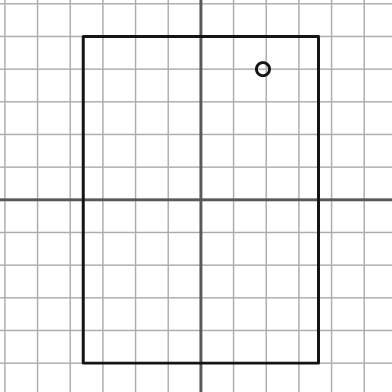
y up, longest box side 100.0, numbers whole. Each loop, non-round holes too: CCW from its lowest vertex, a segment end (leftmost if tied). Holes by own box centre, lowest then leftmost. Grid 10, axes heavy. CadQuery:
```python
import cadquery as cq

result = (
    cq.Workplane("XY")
    .moveTo(-36.0, -50.0)
    .lineTo(36.0, -50.0)
    .lineTo(36.0, 50.0)
    .lineTo(-36.0, 50.0)
    .close()
    .moveTo(19.0, 40.0)
    .circle(2.0)
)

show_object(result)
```